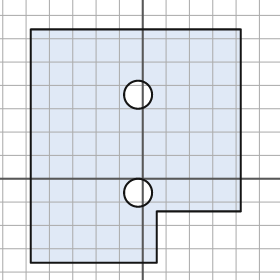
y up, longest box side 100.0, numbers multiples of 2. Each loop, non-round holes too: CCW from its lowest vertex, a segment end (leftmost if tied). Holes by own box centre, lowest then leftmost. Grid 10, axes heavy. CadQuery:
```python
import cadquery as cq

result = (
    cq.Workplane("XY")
    .moveTo(-48.0, -36.0)
    .lineTo(6.0, -36.0)
    .lineTo(6.0, -14.0)
    .lineTo(42.0, -14.0)
    .lineTo(42.0, 64.0)
    .lineTo(-48.0, 64.0)
    .close()
    .moveTo(-2.0, -6.0)
    .circle(6.0)
    .moveTo(-2.0, 36.0)
    .circle(6.0)
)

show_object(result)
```